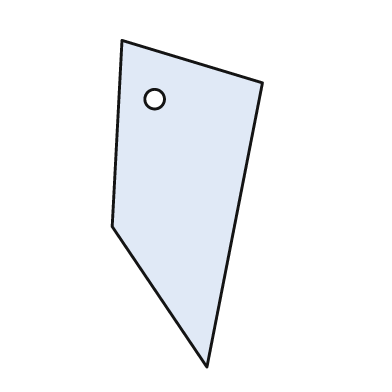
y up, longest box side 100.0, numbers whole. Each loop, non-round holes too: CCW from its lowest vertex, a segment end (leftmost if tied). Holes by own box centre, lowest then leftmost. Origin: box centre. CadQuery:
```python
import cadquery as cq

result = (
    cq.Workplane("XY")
    .moveTo(6.0, -50.0)
    .lineTo(23.0, 37.0)
    .lineTo(-20.0, 50.0)
    .lineTo(-23.0, -7.0)
    .close()
    .moveTo(-10.0, 32.0)
    .circle(3.0)
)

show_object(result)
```